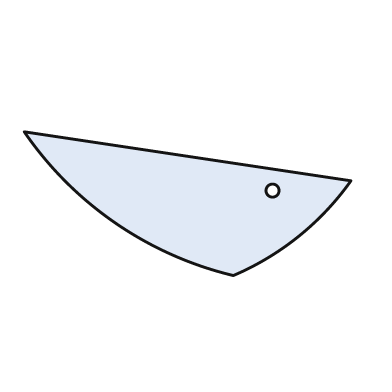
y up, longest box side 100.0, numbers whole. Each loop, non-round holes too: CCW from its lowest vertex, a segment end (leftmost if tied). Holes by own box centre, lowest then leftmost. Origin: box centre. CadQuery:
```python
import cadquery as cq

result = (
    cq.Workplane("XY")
    .moveTo(14.0, -22.0)
    .threePointArc((34.0, -10.0), (50.0, 7.0))
    .lineTo(-50.0, 22.0)
    .threePointArc((-22.0, -6.0), (14.0, -22.0))
    .close()
    .moveTo(26.0, 4.0)
    .circle(2.0)
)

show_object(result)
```